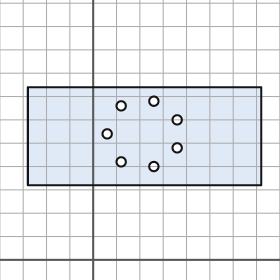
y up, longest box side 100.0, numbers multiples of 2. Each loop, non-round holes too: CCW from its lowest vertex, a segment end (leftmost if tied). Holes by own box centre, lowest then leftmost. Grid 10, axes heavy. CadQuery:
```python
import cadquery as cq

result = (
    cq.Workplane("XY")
    .moveTo(-28.0, 32.0)
    .lineTo(72.0, 32.0)
    .lineTo(72.0, 74.0)
    .lineTo(-28.0, 74.0)
    .close()
    .moveTo(26.0, 40.0)
    .circle(2.0)
    .moveTo(12.0, 42.0)
    .circle(2.0)
    .moveTo(36.0, 48.0)
    .circle(2.0)
    .moveTo(6.0, 54.0)
    .circle(2.0)
    .moveTo(36.0, 60.0)
    .circle(2.0)
    .moveTo(12.0, 66.0)
    .circle(2.0)
    .moveTo(26.0, 68.0)
    .circle(2.0)
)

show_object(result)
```